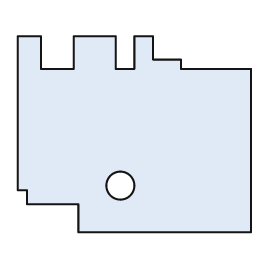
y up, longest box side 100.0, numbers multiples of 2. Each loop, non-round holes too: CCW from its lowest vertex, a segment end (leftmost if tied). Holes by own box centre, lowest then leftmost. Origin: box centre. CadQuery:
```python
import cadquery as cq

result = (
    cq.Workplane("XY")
    .moveTo(-24.0, -42.0)
    .lineTo(50.0, -42.0)
    .lineTo(50.0, 28.0)
    .lineTo(20.0, 28.0)
    .lineTo(20.0, 32.0)
    .lineTo(8.0, 32.0)
    .lineTo(8.0, 42.0)
    .lineTo(0.0, 42.0)
    .lineTo(0.0, 28.0)
    .lineTo(-8.0, 28.0)
    .lineTo(-8.0, 42.0)
    .lineTo(-26.0, 42.0)
    .lineTo(-26.0, 28.0)
    .lineTo(-40.0, 28.0)
    .lineTo(-40.0, 42.0)
    .lineTo(-50.0, 42.0)
    .lineTo(-50.0, -24.0)
    .lineTo(-46.0, -24.0)
    .lineTo(-46.0, -30.0)
    .lineTo(-24.0, -30.0)
    .close()
    .moveTo(-6.0, -22.0)
    .circle(6.0)
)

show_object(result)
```